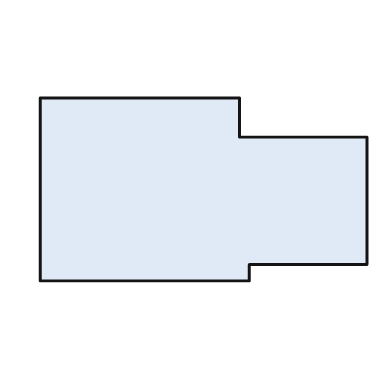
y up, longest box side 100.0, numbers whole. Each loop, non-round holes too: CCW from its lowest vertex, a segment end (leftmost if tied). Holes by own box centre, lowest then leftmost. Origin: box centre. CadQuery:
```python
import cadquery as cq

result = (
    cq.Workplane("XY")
    .moveTo(-50.0, -28.0)
    .lineTo(14.0, -28.0)
    .lineTo(14.0, -23.0)
    .lineTo(50.0, -23.0)
    .lineTo(50.0, 16.0)
    .lineTo(11.0, 16.0)
    .lineTo(11.0, 28.0)
    .lineTo(-50.0, 28.0)
    .close()
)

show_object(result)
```